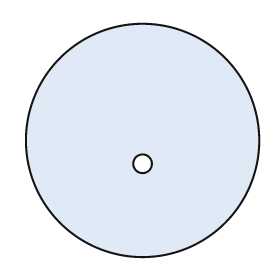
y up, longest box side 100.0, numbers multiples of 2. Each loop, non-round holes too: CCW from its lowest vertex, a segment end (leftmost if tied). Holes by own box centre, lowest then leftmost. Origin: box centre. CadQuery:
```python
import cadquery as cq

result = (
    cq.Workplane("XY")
    .moveTo(0.0, 0.0)
    .circle(50.0)
    .moveTo(0.0, -10.0)
    .circle(4.0)
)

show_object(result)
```